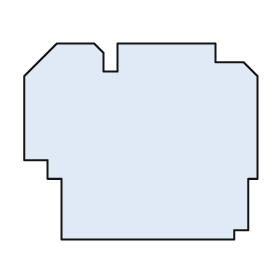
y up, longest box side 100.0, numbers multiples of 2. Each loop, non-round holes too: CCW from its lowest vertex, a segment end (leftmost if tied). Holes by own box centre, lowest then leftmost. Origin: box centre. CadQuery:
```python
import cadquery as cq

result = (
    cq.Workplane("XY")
    .moveTo(-34.0, -42.0)
    .lineTo(40.0, -42.0)
    .lineTo(40.0, -38.0)
    .lineTo(46.0, -38.0)
    .lineTo(46.0, -16.0)
    .lineTo(50.0, -16.0)
    .lineTo(50.0, 28.0)
    .lineTo(44.0, 34.0)
    .lineTo(32.0, 34.0)
    .lineTo(32.0, 42.0)
    .lineTo(-10.0, 42.0)
    .lineTo(-10.0, 30.0)
    .lineTo(-16.0, 30.0)
    .lineTo(-16.0, 38.0)
    .lineTo(-20.0, 42.0)
    .lineTo(-36.0, 42.0)
    .lineTo(-50.0, 28.0)
    .lineTo(-50.0, -8.0)
    .lineTo(-40.0, -8.0)
    .lineTo(-40.0, -16.0)
    .lineTo(-34.0, -16.0)
    .close()
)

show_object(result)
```